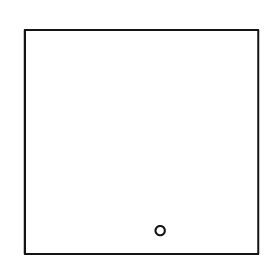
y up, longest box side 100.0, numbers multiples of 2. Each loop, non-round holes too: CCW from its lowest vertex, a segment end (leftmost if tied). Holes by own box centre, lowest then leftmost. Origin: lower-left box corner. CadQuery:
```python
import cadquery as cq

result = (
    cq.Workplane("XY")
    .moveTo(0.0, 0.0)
    .lineTo(100.0, 0.0)
    .lineTo(100.0, 96.0)
    .lineTo(0.0, 96.0)
    .close()
    .moveTo(58.0, 10.0)
    .circle(2.0)
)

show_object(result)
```